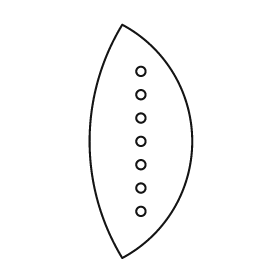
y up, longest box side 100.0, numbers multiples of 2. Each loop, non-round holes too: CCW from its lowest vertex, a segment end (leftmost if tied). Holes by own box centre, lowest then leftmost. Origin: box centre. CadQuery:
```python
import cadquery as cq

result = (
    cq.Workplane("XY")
    .moveTo(-8.0, -50.0)
    .threePointArc((22.0, 0.0), (-8.0, 50.0))
    .threePointArc((-22.0, 0.0), (-8.0, -50.0))
    .close()
    .moveTo(0.0, -30.0)
    .circle(2.0)
    .moveTo(0.0, -20.0)
    .circle(2.0)
    .moveTo(0.0, -10.0)
    .circle(2.0)
    .moveTo(0.0, 0.0)
    .circle(2.0)
    .moveTo(0.0, 10.0)
    .circle(2.0)
    .moveTo(0.0, 20.0)
    .circle(2.0)
    .moveTo(0.0, 30.0)
    .circle(2.0)
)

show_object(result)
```